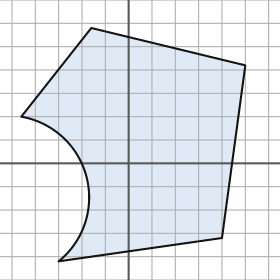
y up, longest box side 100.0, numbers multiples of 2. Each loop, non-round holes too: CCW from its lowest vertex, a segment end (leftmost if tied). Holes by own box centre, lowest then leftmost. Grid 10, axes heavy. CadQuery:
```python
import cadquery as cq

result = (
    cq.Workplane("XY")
    .moveTo(-30.0, -42.0)
    .lineTo(40.0, -32.0)
    .lineTo(50.0, 42.0)
    .lineTo(-16.0, 58.0)
    .lineTo(-46.0, 20.0)
    .threePointArc((-18.0, -6.0), (-30.0, -42.0))
    .close()
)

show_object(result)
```